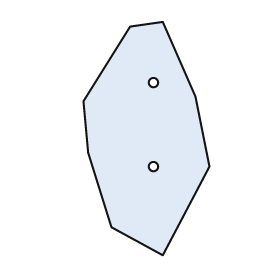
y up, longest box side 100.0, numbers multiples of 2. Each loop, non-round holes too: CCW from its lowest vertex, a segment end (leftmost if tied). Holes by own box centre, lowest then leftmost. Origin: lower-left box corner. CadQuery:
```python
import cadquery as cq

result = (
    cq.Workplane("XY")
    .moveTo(34.0, 0.0)
    .lineTo(54.0, 38.0)
    .lineTo(48.0, 68.0)
    .lineTo(34.0, 100.0)
    .lineTo(20.0, 98.0)
    .lineTo(0.0, 66.0)
    .lineTo(2.0, 44.0)
    .lineTo(12.0, 12.0)
    .close()
    .moveTo(30.0, 38.0)
    .circle(2.0)
    .moveTo(30.0, 74.0)
    .circle(2.0)
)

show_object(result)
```